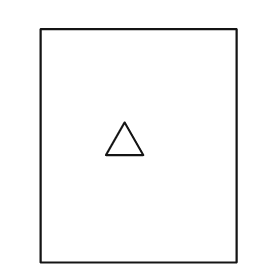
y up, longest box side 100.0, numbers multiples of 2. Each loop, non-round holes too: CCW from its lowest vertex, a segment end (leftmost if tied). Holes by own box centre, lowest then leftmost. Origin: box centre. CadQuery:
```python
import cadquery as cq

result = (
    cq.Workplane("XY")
    .moveTo(-42.0, -50.0)
    .lineTo(42.0, -50.0)
    .lineTo(42.0, 50.0)
    .lineTo(-42.0, 50.0)
    .close()
    .moveTo(-14.0, -4.0)
    .lineTo(2.0, -4.0)
    .lineTo(-6.0, 10.0)
    .close()
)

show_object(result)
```